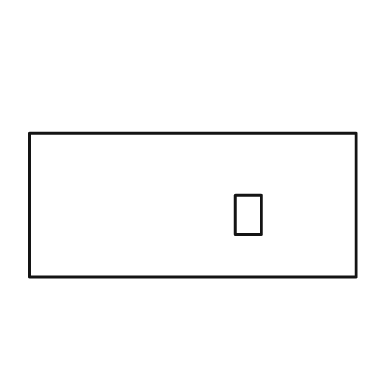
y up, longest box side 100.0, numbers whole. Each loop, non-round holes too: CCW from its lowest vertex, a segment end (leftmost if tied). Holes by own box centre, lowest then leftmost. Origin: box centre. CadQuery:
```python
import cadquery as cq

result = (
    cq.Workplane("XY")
    .moveTo(-50.0, -22.0)
    .lineTo(50.0, -22.0)
    .lineTo(50.0, 22.0)
    .lineTo(-50.0, 22.0)
    .close()
    .moveTo(13.0, -9.0)
    .lineTo(21.0, -9.0)
    .lineTo(21.0, 3.0)
    .lineTo(13.0, 3.0)
    .close()
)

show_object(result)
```